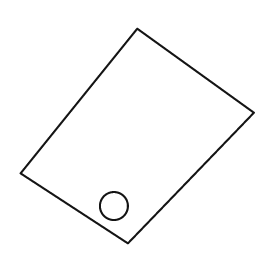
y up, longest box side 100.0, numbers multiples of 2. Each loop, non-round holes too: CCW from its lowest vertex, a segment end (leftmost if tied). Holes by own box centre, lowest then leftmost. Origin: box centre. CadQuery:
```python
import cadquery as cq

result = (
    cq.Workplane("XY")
    .moveTo(-4.0, -46.0)
    .lineTo(50.0, 10.0)
    .lineTo(0.0, 46.0)
    .lineTo(-50.0, -16.0)
    .close()
    .moveTo(-10.0, -30.0)
    .circle(6.0)
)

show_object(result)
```